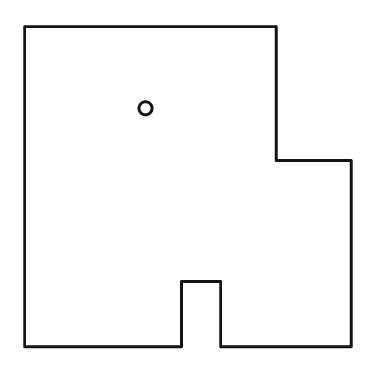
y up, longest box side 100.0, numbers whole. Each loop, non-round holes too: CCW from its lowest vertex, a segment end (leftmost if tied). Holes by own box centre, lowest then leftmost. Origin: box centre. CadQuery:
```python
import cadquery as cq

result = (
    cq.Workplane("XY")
    .moveTo(-50.0, -49.0)
    .lineTo(-2.0, -49.0)
    .lineTo(-2.0, -29.0)
    .lineTo(10.0, -29.0)
    .lineTo(10.0, -49.0)
    .lineTo(50.0, -49.0)
    .lineTo(50.0, 8.0)
    .lineTo(27.0, 8.0)
    .lineTo(27.0, 49.0)
    .lineTo(-50.0, 49.0)
    .close()
    .moveTo(-13.0, 24.0)
    .circle(2.0)
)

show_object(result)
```